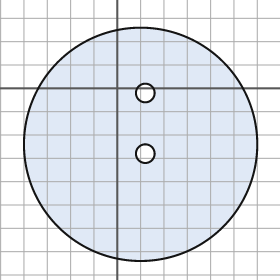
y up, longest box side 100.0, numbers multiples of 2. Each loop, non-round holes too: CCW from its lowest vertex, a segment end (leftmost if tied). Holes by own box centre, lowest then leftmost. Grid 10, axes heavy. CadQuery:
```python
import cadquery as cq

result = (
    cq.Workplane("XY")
    .moveTo(10.0, -24.0)
    .circle(50.0)
    .moveTo(12.0, -28.0)
    .circle(4.0)
    .moveTo(12.0, -2.0)
    .circle(4.0)
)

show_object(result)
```